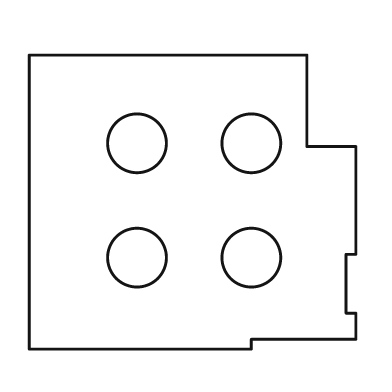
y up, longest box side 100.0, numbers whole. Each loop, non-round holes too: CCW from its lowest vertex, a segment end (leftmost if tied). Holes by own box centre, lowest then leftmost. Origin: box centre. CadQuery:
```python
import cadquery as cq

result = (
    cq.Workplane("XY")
    .moveTo(-50.0, -45.0)
    .lineTo(18.0, -45.0)
    .lineTo(18.0, -42.0)
    .lineTo(50.0, -42.0)
    .lineTo(50.0, -34.0)
    .lineTo(47.0, -34.0)
    .lineTo(47.0, -16.0)
    .lineTo(50.0, -16.0)
    .lineTo(50.0, 17.0)
    .lineTo(35.0, 17.0)
    .lineTo(35.0, 45.0)
    .lineTo(-50.0, 45.0)
    .close()
    .moveTo(-17.0, -17.0)
    .circle(9.0)
    .moveTo(18.0, -17.0)
    .circle(9.0)
    .moveTo(-17.0, 18.0)
    .circle(9.0)
    .moveTo(18.0, 18.0)
    .circle(9.0)
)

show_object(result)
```